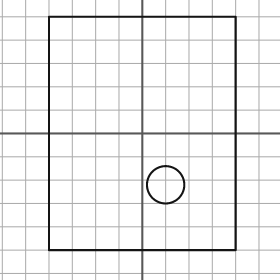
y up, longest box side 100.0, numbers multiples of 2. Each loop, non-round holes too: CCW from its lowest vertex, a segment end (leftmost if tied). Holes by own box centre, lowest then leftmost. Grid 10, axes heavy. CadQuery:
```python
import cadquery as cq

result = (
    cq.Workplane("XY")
    .moveTo(-40.0, -50.0)
    .lineTo(40.0, -50.0)
    .lineTo(40.0, 50.0)
    .lineTo(-40.0, 50.0)
    .close()
    .moveTo(10.0, -22.0)
    .circle(8.0)
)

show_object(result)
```